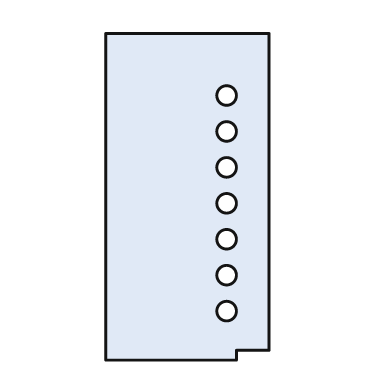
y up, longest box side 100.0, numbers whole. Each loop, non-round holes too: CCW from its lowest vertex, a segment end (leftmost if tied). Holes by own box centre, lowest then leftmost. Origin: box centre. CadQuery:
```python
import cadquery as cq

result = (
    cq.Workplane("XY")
    .moveTo(-25.0, -50.0)
    .lineTo(15.0, -50.0)
    .lineTo(15.0, -47.0)
    .lineTo(25.0, -47.0)
    .lineTo(25.0, 50.0)
    .lineTo(-25.0, 50.0)
    .close()
    .moveTo(12.0, -35.0)
    .circle(3.0)
    .moveTo(12.0, -24.0)
    .circle(3.0)
    .moveTo(12.0, -13.0)
    .circle(3.0)
    .moveTo(12.0, -2.0)
    .circle(3.0)
    .moveTo(12.0, 9.0)
    .circle(3.0)
    .moveTo(12.0, 20.0)
    .circle(3.0)
    .moveTo(12.0, 31.0)
    .circle(3.0)
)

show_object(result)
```